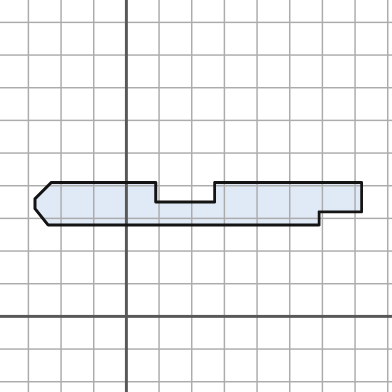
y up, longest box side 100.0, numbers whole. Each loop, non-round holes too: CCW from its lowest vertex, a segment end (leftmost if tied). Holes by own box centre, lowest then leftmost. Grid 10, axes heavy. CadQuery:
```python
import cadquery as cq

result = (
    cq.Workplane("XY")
    .moveTo(-24.0, 28.0)
    .lineTo(59.0, 28.0)
    .lineTo(59.0, 32.0)
    .lineTo(72.0, 32.0)
    .lineTo(72.0, 41.0)
    .lineTo(27.0, 41.0)
    .lineTo(27.0, 35.0)
    .lineTo(9.0, 35.0)
    .lineTo(9.0, 41.0)
    .lineTo(-23.0, 41.0)
    .lineTo(-28.0, 36.0)
    .lineTo(-28.0, 33.0)
    .close()
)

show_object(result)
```